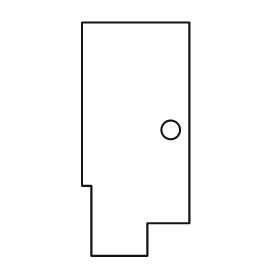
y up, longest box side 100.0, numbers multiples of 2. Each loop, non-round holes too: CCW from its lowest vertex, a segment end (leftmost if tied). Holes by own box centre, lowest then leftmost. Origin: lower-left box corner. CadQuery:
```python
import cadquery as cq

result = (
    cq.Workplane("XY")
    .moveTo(4.0, 0.0)
    .lineTo(28.0, 0.0)
    .lineTo(28.0, 14.0)
    .lineTo(46.0, 14.0)
    .lineTo(46.0, 100.0)
    .lineTo(0.0, 100.0)
    .lineTo(0.0, 30.0)
    .lineTo(4.0, 30.0)
    .close()
    .moveTo(38.0, 54.0)
    .circle(4.0)
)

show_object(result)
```